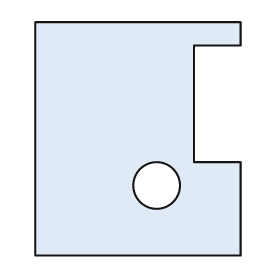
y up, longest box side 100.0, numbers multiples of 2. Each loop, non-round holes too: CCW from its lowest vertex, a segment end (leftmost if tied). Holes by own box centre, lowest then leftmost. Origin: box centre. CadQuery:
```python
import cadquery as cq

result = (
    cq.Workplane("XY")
    .moveTo(-44.0, -50.0)
    .lineTo(44.0, -50.0)
    .lineTo(44.0, -10.0)
    .lineTo(24.0, -10.0)
    .lineTo(24.0, 40.0)
    .lineTo(44.0, 40.0)
    .lineTo(44.0, 50.0)
    .lineTo(-44.0, 50.0)
    .close()
    .moveTo(8.0, -20.0)
    .circle(10.0)
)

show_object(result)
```